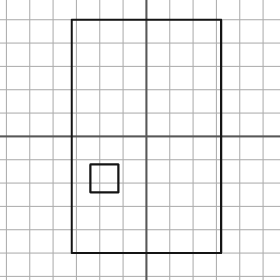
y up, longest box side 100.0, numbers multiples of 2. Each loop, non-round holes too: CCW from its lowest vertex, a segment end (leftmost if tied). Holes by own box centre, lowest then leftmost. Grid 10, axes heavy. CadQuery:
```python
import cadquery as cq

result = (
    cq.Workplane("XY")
    .moveTo(-32.0, -50.0)
    .lineTo(32.0, -50.0)
    .lineTo(32.0, 50.0)
    .lineTo(-32.0, 50.0)
    .close()
    .moveTo(-24.0, -24.0)
    .lineTo(-12.0, -24.0)
    .lineTo(-12.0, -12.0)
    .lineTo(-24.0, -12.0)
    .close()
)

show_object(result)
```